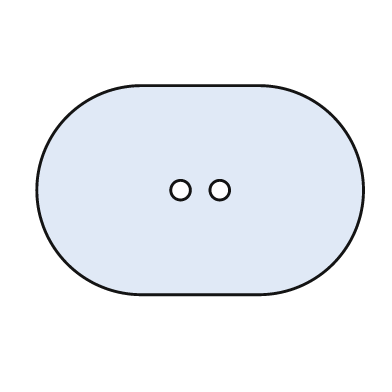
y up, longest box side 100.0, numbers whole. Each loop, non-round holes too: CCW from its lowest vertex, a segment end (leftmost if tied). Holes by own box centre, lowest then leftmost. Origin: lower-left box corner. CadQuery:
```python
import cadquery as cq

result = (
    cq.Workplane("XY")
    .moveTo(32.0, 0.0)
    .lineTo(68.0, 0.0)
    .threePointArc((100.0, 32.0), (68.0, 64.0))
    .lineTo(32.0, 64.0)
    .threePointArc((0.0, 32.0), (32.0, 0.0))
    .close()
    .moveTo(44.0, 32.0)
    .circle(3.0)
    .moveTo(56.0, 32.0)
    .circle(3.0)
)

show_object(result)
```